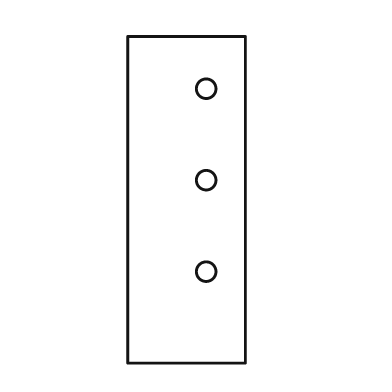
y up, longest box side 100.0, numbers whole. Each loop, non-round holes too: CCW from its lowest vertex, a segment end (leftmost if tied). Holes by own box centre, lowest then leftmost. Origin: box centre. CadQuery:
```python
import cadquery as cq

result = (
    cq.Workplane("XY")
    .moveTo(-18.0, -50.0)
    .lineTo(18.0, -50.0)
    .lineTo(18.0, 50.0)
    .lineTo(-18.0, 50.0)
    .close()
    .moveTo(6.0, -22.0)
    .circle(3.0)
    .moveTo(6.0, 6.0)
    .circle(3.0)
    .moveTo(6.0, 34.0)
    .circle(3.0)
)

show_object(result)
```